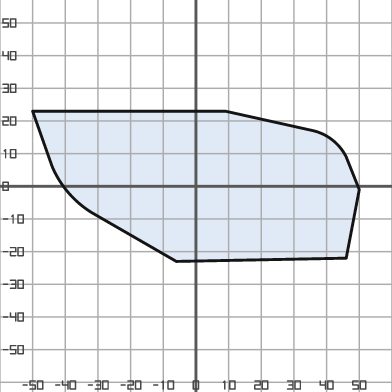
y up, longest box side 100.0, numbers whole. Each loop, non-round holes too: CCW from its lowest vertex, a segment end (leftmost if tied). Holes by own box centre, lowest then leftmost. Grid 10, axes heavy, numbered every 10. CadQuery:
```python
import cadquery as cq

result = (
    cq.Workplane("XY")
    .moveTo(-6.0, -23.0)
    .lineTo(46.0, -22.0)
    .lineTo(50.0, -1.0)
    .lineTo(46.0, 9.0)
    .threePointArc((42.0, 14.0), (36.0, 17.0))
    .lineTo(9.0, 23.0)
    .lineTo(-50.0, 23.0)
    .lineTo(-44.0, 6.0)
    .threePointArc((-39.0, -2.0), (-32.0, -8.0))
    .close()
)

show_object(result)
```